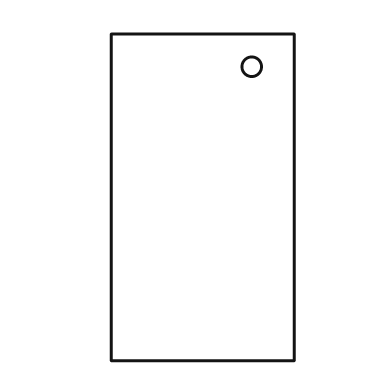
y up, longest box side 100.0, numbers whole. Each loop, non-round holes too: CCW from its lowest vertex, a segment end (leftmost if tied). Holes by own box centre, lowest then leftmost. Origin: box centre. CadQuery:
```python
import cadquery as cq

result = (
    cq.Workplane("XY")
    .moveTo(-28.0, -50.0)
    .lineTo(28.0, -50.0)
    .lineTo(28.0, 50.0)
    .lineTo(-28.0, 50.0)
    .close()
    .moveTo(15.0, 40.0)
    .circle(3.0)
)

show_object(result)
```